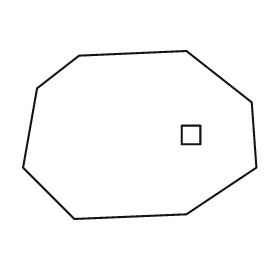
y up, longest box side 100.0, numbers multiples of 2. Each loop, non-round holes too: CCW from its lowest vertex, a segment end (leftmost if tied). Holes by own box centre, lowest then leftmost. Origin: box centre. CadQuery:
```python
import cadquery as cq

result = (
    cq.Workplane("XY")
    .moveTo(-28.0, -36.0)
    .lineTo(20.0, -34.0)
    .lineTo(50.0, -14.0)
    .lineTo(48.0, 14.0)
    .lineTo(20.0, 36.0)
    .lineTo(-26.0, 34.0)
    .lineTo(-44.0, 20.0)
    .lineTo(-50.0, -14.0)
    .close()
    .moveTo(18.0, -4.0)
    .lineTo(26.0, -4.0)
    .lineTo(26.0, 4.0)
    .lineTo(18.0, 4.0)
    .close()
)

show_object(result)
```